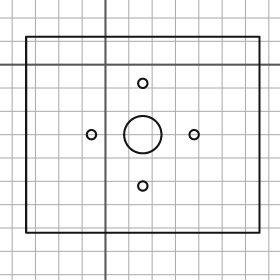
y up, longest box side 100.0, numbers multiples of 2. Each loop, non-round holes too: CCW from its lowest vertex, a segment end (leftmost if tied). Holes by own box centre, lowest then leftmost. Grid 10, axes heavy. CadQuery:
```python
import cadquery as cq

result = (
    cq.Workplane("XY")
    .moveTo(-34.0, -72.0)
    .lineTo(66.0, -72.0)
    .lineTo(66.0, 12.0)
    .lineTo(-34.0, 12.0)
    .close()
    .moveTo(16.0, -52.0)
    .circle(2.0)
    .moveTo(-6.0, -30.0)
    .circle(2.0)
    .moveTo(16.0, -30.0)
    .circle(8.0)
    .moveTo(38.0, -30.0)
    .circle(2.0)
    .moveTo(16.0, -8.0)
    .circle(2.0)
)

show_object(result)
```